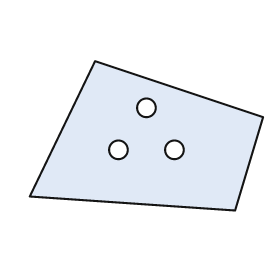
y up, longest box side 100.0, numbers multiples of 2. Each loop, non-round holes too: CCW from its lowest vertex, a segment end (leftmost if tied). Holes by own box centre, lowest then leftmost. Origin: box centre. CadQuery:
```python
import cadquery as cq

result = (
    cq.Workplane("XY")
    .moveTo(38.0, -32.0)
    .lineTo(50.0, 8.0)
    .lineTo(-22.0, 32.0)
    .lineTo(-50.0, -26.0)
    .close()
    .moveTo(-12.0, -6.0)
    .circle(4.0)
    .moveTo(12.0, -6.0)
    .circle(4.0)
    .moveTo(0.0, 12.0)
    .circle(4.0)
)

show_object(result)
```